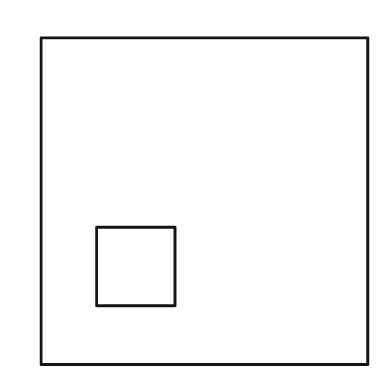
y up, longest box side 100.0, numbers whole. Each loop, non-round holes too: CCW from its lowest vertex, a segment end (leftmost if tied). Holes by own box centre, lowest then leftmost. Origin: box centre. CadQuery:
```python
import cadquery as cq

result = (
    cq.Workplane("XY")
    .moveTo(-50.0, -50.0)
    .lineTo(50.0, -50.0)
    .lineTo(50.0, 50.0)
    .lineTo(-50.0, 50.0)
    .close()
    .moveTo(-33.0, -32.0)
    .lineTo(-9.0, -32.0)
    .lineTo(-9.0, -8.0)
    .lineTo(-33.0, -8.0)
    .close()
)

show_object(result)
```